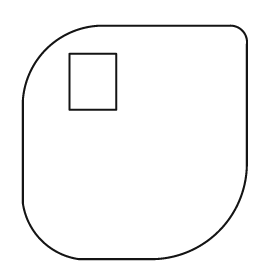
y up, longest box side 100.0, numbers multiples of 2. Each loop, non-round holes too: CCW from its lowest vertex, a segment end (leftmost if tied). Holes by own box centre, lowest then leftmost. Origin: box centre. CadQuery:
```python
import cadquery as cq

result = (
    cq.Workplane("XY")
    .moveTo(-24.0, -50.0)
    .lineTo(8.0, -50.0)
    .threePointArc((36.0, -38.0), (48.0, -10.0))
    .lineTo(48.0, 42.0)
    .threePointArc((46.0, 48.0), (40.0, 50.0))
    .lineTo(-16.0, 50.0)
    .threePointArc((-38.0, 40.0), (-48.0, 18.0))
    .lineTo(-48.0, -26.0)
    .threePointArc((-40.0, -42.0), (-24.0, -50.0))
    .close()
    .moveTo(-28.0, 14.0)
    .lineTo(-8.0, 14.0)
    .lineTo(-8.0, 38.0)
    .lineTo(-28.0, 38.0)
    .close()
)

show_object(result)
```